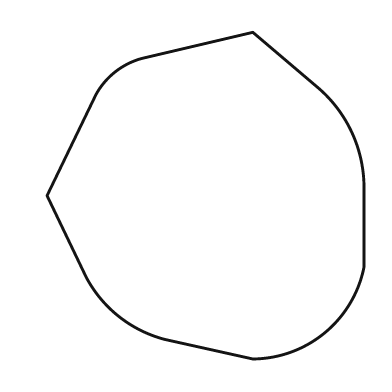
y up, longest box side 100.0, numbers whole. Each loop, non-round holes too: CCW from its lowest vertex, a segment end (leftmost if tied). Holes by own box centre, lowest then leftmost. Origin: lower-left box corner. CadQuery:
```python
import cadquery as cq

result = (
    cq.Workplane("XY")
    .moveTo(63.0, 0.0)
    .threePointArc((85.0, 8.0), (97.0, 28.0))
    .lineTo(97.0, 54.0)
    .threePointArc((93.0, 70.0), (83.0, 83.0))
    .lineTo(63.0, 100.0)
    .lineTo(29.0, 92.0)
    .threePointArc((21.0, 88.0), (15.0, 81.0))
    .lineTo(0.0, 50.0)
    .lineTo(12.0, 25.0)
    .threePointArc((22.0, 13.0), (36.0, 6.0))
    .close()
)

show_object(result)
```